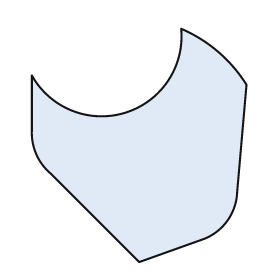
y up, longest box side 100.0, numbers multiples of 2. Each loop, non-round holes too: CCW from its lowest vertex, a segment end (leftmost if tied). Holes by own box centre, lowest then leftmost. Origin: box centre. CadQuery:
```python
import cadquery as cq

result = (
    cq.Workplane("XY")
    .moveTo(0.0, -50.0)
    .lineTo(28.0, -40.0)
    .threePointArc((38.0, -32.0), (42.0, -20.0))
    .lineTo(46.0, 26.0)
    .threePointArc((34.0, 40.0), (18.0, 50.0))
    .threePointArc((-6.0, 14.0), (-46.0, 30.0))
    .lineTo(-46.0, 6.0)
    .threePointArc((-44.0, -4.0), (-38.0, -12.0))
    .close()
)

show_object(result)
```